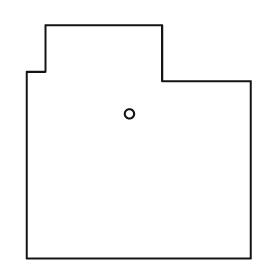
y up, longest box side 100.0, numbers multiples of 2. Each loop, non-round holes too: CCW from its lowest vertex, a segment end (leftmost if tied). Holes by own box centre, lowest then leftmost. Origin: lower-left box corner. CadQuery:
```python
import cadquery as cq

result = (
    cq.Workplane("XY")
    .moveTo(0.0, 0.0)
    .lineTo(96.0, 0.0)
    .lineTo(96.0, 76.0)
    .lineTo(58.0, 76.0)
    .lineTo(58.0, 100.0)
    .lineTo(8.0, 100.0)
    .lineTo(8.0, 80.0)
    .lineTo(0.0, 80.0)
    .close()
    .moveTo(44.0, 62.0)
    .circle(2.0)
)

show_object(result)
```